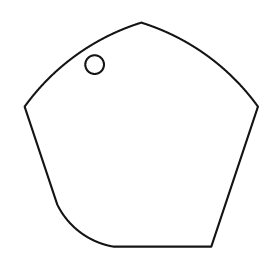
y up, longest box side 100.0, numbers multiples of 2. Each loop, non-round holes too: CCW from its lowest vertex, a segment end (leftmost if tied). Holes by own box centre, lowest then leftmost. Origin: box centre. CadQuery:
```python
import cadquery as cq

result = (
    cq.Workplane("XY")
    .moveTo(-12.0, -48.0)
    .lineTo(30.0, -48.0)
    .lineTo(50.0, 12.0)
    .threePointArc((28.0, 34.0), (0.0, 48.0))
    .threePointArc((-28.0, 34.0), (-50.0, 12.0))
    .lineTo(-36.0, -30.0)
    .threePointArc((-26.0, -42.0), (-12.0, -48.0))
    .close()
    .moveTo(-20.0, 30.0)
    .circle(4.0)
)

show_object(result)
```